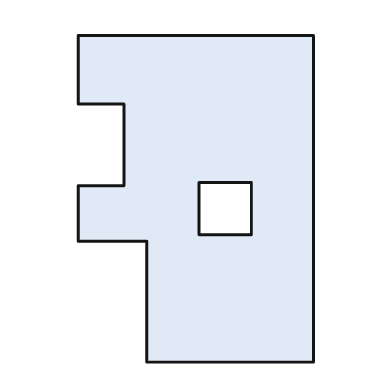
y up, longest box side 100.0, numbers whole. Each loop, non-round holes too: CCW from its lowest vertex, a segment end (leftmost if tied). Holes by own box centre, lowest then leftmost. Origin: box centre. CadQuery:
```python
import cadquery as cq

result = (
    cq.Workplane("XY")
    .moveTo(-15.0, -50.0)
    .lineTo(36.0, -50.0)
    .lineTo(36.0, 50.0)
    .lineTo(-36.0, 50.0)
    .lineTo(-36.0, 29.0)
    .lineTo(-22.0, 29.0)
    .lineTo(-22.0, 4.0)
    .lineTo(-36.0, 4.0)
    .lineTo(-36.0, -13.0)
    .lineTo(-15.0, -13.0)
    .close()
    .moveTo(1.0, -11.0)
    .lineTo(17.0, -11.0)
    .lineTo(17.0, 5.0)
    .lineTo(1.0, 5.0)
    .close()
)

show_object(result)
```